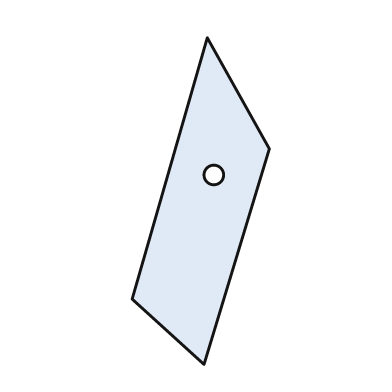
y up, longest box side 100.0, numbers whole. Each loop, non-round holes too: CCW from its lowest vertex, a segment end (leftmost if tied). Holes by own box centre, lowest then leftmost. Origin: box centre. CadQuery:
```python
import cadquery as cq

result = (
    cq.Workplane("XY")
    .moveTo(1.0, -50.0)
    .lineTo(21.0, 16.0)
    .lineTo(2.0, 50.0)
    .lineTo(-21.0, -30.0)
    .close()
    .moveTo(4.0, 8.0)
    .circle(3.0)
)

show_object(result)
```